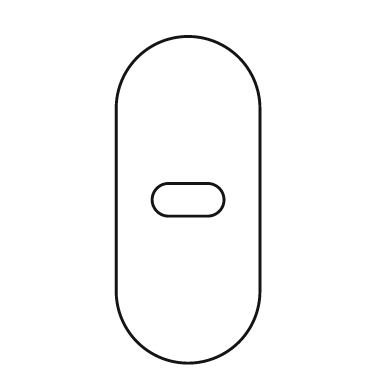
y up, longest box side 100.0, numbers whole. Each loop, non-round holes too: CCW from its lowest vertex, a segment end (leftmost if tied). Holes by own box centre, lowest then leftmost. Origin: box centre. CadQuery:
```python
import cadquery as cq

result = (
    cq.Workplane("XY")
    .moveTo(-22.0, -28.0)
    .threePointArc((0.0, -50.0), (22.0, -28.0))
    .lineTo(22.0, 28.0)
    .threePointArc((0.0, 50.0), (-22.0, 28.0))
    .close()
    .moveTo(-6.0, -5.0)
    .lineTo(6.0, -5.0)
    .threePointArc((11.0, 0.0), (6.0, 5.0))
    .lineTo(-6.0, 5.0)
    .threePointArc((-11.0, 0.0), (-6.0, -5.0))
    .close()
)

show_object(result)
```